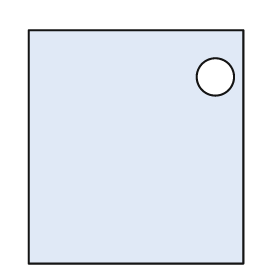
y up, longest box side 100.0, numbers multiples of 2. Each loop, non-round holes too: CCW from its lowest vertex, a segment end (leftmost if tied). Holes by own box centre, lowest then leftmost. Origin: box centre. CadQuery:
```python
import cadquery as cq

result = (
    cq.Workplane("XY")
    .moveTo(-46.0, -50.0)
    .lineTo(46.0, -50.0)
    .lineTo(46.0, 50.0)
    .lineTo(-46.0, 50.0)
    .close()
    .moveTo(34.0, 30.0)
    .circle(8.0)
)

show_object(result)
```